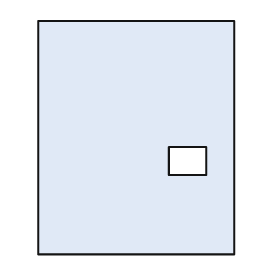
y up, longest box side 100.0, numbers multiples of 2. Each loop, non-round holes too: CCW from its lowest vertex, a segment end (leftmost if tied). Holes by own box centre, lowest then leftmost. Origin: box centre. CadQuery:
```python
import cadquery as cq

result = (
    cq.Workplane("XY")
    .moveTo(-42.0, -50.0)
    .lineTo(42.0, -50.0)
    .lineTo(42.0, 50.0)
    .lineTo(-42.0, 50.0)
    .close()
    .moveTo(14.0, -16.0)
    .lineTo(30.0, -16.0)
    .lineTo(30.0, -4.0)
    .lineTo(14.0, -4.0)
    .close()
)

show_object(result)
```